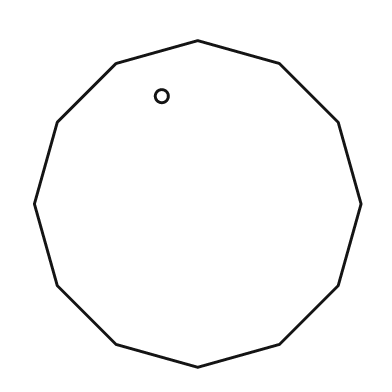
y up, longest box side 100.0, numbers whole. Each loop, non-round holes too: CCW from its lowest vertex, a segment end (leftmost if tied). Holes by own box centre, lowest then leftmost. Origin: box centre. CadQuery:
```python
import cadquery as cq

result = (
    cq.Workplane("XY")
    .moveTo(0.0, -50.0)
    .lineTo(25.0, -43.0)
    .lineTo(43.0, -25.0)
    .lineTo(50.0, 0.0)
    .lineTo(43.0, 25.0)
    .lineTo(25.0, 43.0)
    .lineTo(0.0, 50.0)
    .lineTo(-25.0, 43.0)
    .lineTo(-43.0, 25.0)
    .lineTo(-50.0, 0.0)
    .lineTo(-43.0, -25.0)
    .lineTo(-25.0, -43.0)
    .close()
    .moveTo(-11.0, 33.0)
    .circle(2.0)
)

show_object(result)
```